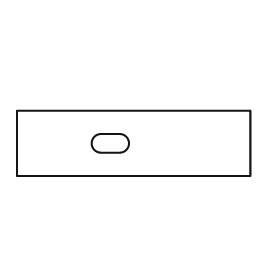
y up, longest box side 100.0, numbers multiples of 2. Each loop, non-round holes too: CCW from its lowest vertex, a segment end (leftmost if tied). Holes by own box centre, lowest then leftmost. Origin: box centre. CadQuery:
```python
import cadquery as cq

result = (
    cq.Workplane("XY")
    .moveTo(-50.0, -14.0)
    .lineTo(50.0, -14.0)
    .lineTo(50.0, 14.0)
    .lineTo(-50.0, 14.0)
    .close()
    .moveTo(-14.0, -4.0)
    .lineTo(-6.0, -4.0)
    .threePointArc((-2.0, 0.0), (-6.0, 4.0))
    .lineTo(-14.0, 4.0)
    .threePointArc((-18.0, 0.0), (-14.0, -4.0))
    .close()
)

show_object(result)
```